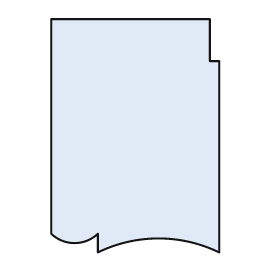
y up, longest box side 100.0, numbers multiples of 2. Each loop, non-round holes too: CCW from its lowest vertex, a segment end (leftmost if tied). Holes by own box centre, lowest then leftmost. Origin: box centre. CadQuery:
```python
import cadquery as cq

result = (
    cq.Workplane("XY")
    .moveTo(-16.0, -50.0)
    .threePointArc((10.0, -44.0), (36.0, -50.0))
    .lineTo(36.0, 32.0)
    .lineTo(32.0, 32.0)
    .lineTo(32.0, 50.0)
    .lineTo(-36.0, 50.0)
    .lineTo(-36.0, -42.0)
    .threePointArc((-26.0, -46.0), (-16.0, -42.0))
    .close()
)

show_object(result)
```